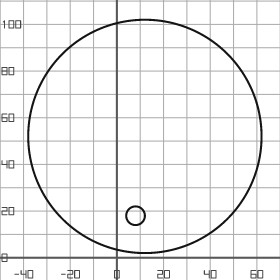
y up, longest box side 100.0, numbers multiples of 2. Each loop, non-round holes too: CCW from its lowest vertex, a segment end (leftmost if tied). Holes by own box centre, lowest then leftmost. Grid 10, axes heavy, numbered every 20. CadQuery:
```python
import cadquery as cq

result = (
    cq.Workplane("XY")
    .moveTo(12.0, 52.0)
    .circle(50.0)
    .moveTo(8.0, 18.0)
    .circle(4.0)
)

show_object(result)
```